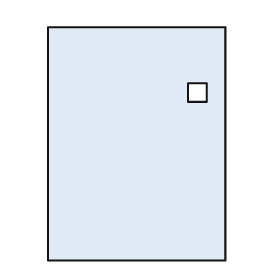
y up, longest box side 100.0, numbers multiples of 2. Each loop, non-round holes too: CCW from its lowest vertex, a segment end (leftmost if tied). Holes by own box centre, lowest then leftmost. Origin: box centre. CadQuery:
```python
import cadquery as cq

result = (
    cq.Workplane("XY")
    .moveTo(-38.0, -50.0)
    .lineTo(38.0, -50.0)
    .lineTo(38.0, 50.0)
    .lineTo(-38.0, 50.0)
    .close()
    .moveTo(22.0, 18.0)
    .lineTo(30.0, 18.0)
    .lineTo(30.0, 26.0)
    .lineTo(22.0, 26.0)
    .close()
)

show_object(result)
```